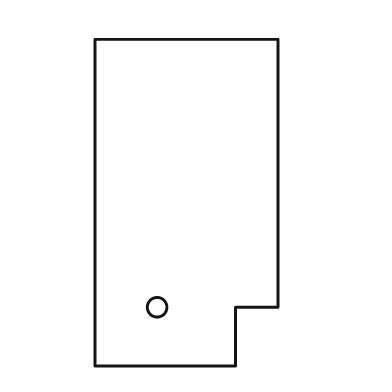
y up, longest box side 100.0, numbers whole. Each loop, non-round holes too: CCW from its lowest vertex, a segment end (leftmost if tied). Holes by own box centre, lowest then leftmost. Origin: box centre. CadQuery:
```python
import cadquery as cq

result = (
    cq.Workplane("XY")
    .moveTo(-28.0, -50.0)
    .lineTo(15.0, -50.0)
    .lineTo(15.0, -32.0)
    .lineTo(28.0, -32.0)
    .lineTo(28.0, 50.0)
    .lineTo(-28.0, 50.0)
    .close()
    .moveTo(-9.0, -32.0)
    .circle(3.0)
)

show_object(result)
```